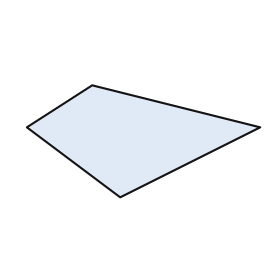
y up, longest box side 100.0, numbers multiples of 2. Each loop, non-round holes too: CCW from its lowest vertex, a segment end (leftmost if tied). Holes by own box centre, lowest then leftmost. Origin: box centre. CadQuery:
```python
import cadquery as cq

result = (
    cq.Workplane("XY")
    .moveTo(-10.0, -24.0)
    .lineTo(50.0, 6.0)
    .lineTo(-22.0, 24.0)
    .lineTo(-50.0, 6.0)
    .close()
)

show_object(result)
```